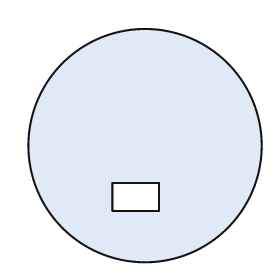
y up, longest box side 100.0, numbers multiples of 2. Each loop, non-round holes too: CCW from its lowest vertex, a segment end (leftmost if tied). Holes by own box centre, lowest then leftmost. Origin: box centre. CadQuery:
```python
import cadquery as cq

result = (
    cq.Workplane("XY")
    .moveTo(0.0, 0.0)
    .circle(50.0)
    .moveTo(-14.0, -28.0)
    .lineTo(6.0, -28.0)
    .lineTo(6.0, -16.0)
    .lineTo(-14.0, -16.0)
    .close()
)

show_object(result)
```